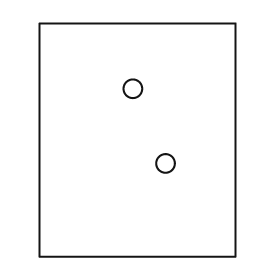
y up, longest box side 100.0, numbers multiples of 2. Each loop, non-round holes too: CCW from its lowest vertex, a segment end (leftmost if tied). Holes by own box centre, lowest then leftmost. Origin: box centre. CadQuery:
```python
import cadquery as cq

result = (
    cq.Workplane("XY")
    .moveTo(-42.0, -50.0)
    .lineTo(42.0, -50.0)
    .lineTo(42.0, 50.0)
    .lineTo(-42.0, 50.0)
    .close()
    .moveTo(12.0, -10.0)
    .circle(4.0)
    .moveTo(-2.0, 22.0)
    .circle(4.0)
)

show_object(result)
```